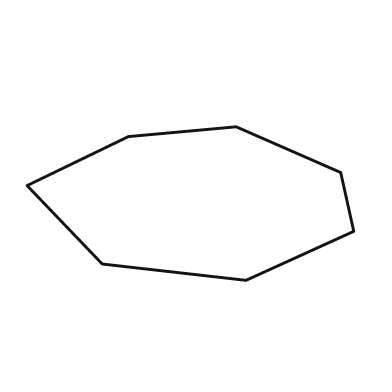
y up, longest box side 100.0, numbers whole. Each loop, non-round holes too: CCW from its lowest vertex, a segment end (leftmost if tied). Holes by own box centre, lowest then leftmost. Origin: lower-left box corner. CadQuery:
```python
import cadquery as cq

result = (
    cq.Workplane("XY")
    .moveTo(67.0, 0.0)
    .lineTo(100.0, 15.0)
    .lineTo(96.0, 33.0)
    .lineTo(64.0, 47.0)
    .lineTo(31.0, 44.0)
    .lineTo(0.0, 29.0)
    .lineTo(23.0, 5.0)
    .close()
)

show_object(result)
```